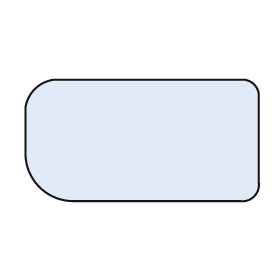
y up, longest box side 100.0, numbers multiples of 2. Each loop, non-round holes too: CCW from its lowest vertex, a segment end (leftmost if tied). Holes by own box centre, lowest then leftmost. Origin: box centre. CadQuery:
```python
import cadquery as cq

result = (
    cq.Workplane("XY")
    .moveTo(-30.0, -26.0)
    .lineTo(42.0, -26.0)
    .threePointArc((48.0, -24.0), (50.0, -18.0))
    .lineTo(50.0, 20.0)
    .threePointArc((48.0, 24.0), (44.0, 26.0))
    .lineTo(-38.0, 26.0)
    .threePointArc((-46.0, 22.0), (-50.0, 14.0))
    .lineTo(-50.0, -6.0)
    .threePointArc((-44.0, -20.0), (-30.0, -26.0))
    .close()
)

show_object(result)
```